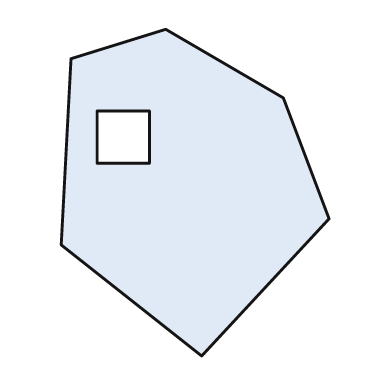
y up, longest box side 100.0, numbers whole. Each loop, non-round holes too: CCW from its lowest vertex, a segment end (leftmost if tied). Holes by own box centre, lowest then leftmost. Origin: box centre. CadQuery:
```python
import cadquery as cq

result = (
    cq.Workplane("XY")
    .moveTo(2.0, -50.0)
    .lineTo(41.0, -8.0)
    .lineTo(27.0, 29.0)
    .lineTo(-9.0, 50.0)
    .lineTo(-38.0, 41.0)
    .lineTo(-41.0, -16.0)
    .close()
    .moveTo(-30.0, 9.0)
    .lineTo(-14.0, 9.0)
    .lineTo(-14.0, 25.0)
    .lineTo(-30.0, 25.0)
    .close()
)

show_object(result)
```